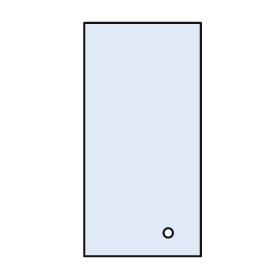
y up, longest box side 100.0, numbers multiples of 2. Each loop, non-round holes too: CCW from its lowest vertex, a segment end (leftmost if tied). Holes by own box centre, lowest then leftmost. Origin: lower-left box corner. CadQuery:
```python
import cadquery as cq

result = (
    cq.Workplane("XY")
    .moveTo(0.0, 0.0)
    .lineTo(50.0, 0.0)
    .lineTo(50.0, 100.0)
    .lineTo(0.0, 100.0)
    .close()
    .moveTo(36.0, 10.0)
    .circle(2.0)
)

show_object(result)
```